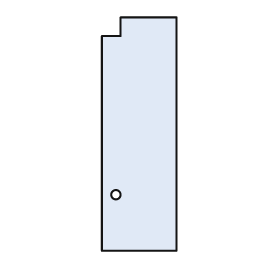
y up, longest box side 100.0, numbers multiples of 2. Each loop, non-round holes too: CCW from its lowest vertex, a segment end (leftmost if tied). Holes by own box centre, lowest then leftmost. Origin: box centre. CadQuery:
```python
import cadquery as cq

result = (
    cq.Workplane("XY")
    .moveTo(-16.0, -50.0)
    .lineTo(16.0, -50.0)
    .lineTo(16.0, 50.0)
    .lineTo(-8.0, 50.0)
    .lineTo(-8.0, 42.0)
    .lineTo(-16.0, 42.0)
    .close()
    .moveTo(-10.0, -26.0)
    .circle(2.0)
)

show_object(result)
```